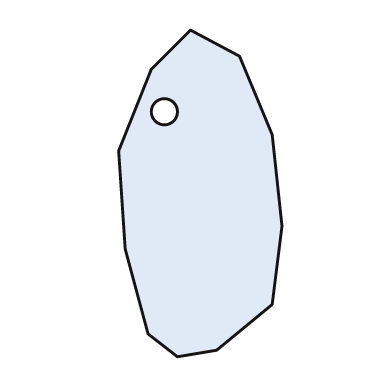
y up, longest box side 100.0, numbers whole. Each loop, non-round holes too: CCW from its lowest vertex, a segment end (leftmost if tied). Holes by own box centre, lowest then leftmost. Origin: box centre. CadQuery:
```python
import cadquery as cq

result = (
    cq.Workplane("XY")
    .moveTo(-7.0, -50.0)
    .lineTo(5.0, -48.0)
    .lineTo(22.0, -34.0)
    .lineTo(25.0, -10.0)
    .lineTo(22.0, 18.0)
    .lineTo(12.0, 42.0)
    .lineTo(-3.0, 50.0)
    .lineTo(-15.0, 38.0)
    .lineTo(-25.0, 13.0)
    .lineTo(-23.0, -17.0)
    .lineTo(-16.0, -43.0)
    .close()
    .moveTo(-11.0, 25.0)
    .circle(4.0)
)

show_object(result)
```